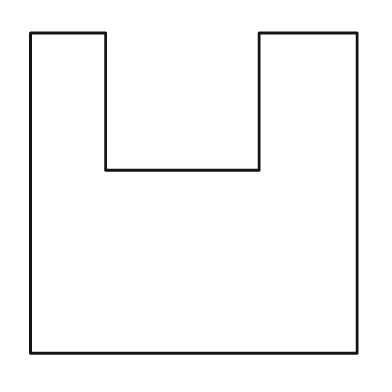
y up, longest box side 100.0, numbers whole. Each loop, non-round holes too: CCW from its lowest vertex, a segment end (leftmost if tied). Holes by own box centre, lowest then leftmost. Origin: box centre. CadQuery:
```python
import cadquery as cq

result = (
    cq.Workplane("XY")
    .moveTo(-50.0, -49.0)
    .lineTo(50.0, -49.0)
    .lineTo(50.0, 49.0)
    .lineTo(20.0, 49.0)
    .lineTo(20.0, 7.0)
    .lineTo(-27.0, 7.0)
    .lineTo(-27.0, 49.0)
    .lineTo(-50.0, 49.0)
    .close()
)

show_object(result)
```